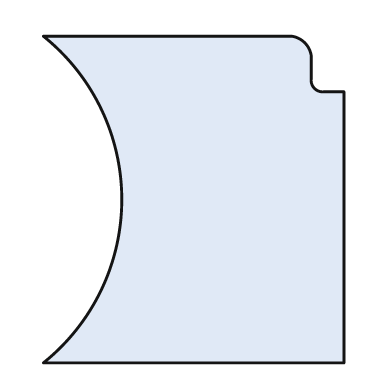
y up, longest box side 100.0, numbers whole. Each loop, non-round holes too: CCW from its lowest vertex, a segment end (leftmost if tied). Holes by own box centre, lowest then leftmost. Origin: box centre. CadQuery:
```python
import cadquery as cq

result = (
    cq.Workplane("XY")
    .moveTo(-46.0, -50.0)
    .lineTo(46.0, -50.0)
    .lineTo(46.0, 33.0)
    .lineTo(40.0, 33.0)
    .threePointArc((37.0, 34.0), (36.0, 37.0))
    .lineTo(36.0, 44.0)
    .threePointArc((34.0, 48.0), (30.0, 50.0))
    .lineTo(-46.0, 50.0)
    .threePointArc((-22.0, 0.0), (-46.0, -50.0))
    .close()
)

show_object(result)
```